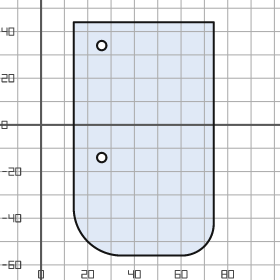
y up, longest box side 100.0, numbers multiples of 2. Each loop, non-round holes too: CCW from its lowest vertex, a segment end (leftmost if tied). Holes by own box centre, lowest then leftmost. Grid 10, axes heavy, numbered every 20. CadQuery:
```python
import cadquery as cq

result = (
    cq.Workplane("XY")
    .moveTo(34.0, -56.0)
    .lineTo(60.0, -56.0)
    .threePointArc((70.0, -52.0), (74.0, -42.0))
    .lineTo(74.0, 44.0)
    .lineTo(14.0, 44.0)
    .lineTo(14.0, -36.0)
    .threePointArc((20.0, -50.0), (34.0, -56.0))
    .close()
    .moveTo(26.0, -14.0)
    .circle(2.0)
    .moveTo(26.0, 34.0)
    .circle(2.0)
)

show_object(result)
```